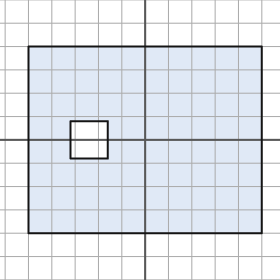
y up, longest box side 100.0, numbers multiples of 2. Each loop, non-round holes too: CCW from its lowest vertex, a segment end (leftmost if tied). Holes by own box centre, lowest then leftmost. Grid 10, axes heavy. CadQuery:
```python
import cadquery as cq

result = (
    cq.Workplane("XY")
    .moveTo(-50.0, -40.0)
    .lineTo(50.0, -40.0)
    .lineTo(50.0, 40.0)
    .lineTo(-50.0, 40.0)
    .close()
    .moveTo(-32.0, -8.0)
    .lineTo(-16.0, -8.0)
    .lineTo(-16.0, 8.0)
    .lineTo(-32.0, 8.0)
    .close()
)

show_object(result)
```